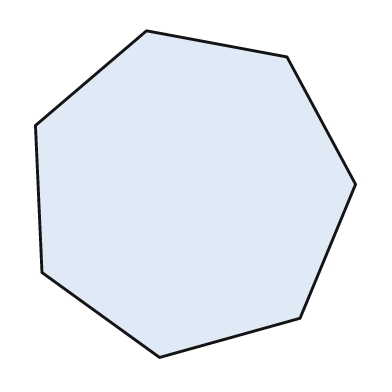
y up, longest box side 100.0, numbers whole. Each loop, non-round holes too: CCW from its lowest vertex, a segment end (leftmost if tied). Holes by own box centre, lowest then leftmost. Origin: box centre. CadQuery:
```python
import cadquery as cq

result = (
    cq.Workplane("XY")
    .moveTo(-11.0, -50.0)
    .lineTo(32.0, -38.0)
    .lineTo(49.0, 3.0)
    .lineTo(28.0, 42.0)
    .lineTo(-15.0, 50.0)
    .lineTo(-49.0, 21.0)
    .lineTo(-47.0, -24.0)
    .close()
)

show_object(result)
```